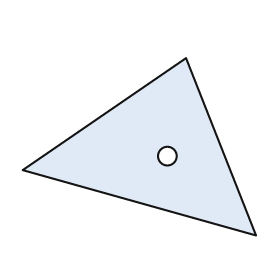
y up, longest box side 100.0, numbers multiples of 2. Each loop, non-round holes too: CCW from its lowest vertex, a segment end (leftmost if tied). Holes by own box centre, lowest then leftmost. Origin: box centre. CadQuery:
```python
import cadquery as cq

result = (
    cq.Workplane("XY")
    .moveTo(50.0, -38.0)
    .lineTo(20.0, 38.0)
    .lineTo(-50.0, -10.0)
    .close()
    .moveTo(12.0, -4.0)
    .circle(4.0)
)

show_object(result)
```